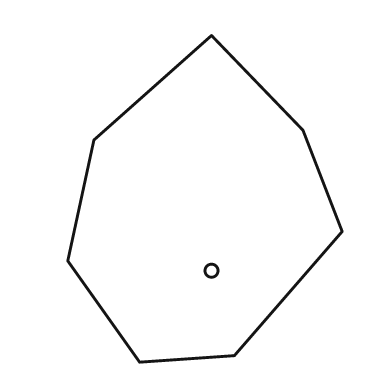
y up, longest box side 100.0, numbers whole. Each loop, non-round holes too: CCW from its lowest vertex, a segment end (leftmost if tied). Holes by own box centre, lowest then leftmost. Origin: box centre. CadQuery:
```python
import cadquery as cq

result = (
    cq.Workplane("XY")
    .moveTo(-20.0, -50.0)
    .lineTo(9.0, -48.0)
    .lineTo(42.0, -10.0)
    .lineTo(30.0, 21.0)
    .lineTo(2.0, 50.0)
    .lineTo(-34.0, 18.0)
    .lineTo(-42.0, -19.0)
    .close()
    .moveTo(2.0, -22.0)
    .circle(2.0)
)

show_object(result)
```